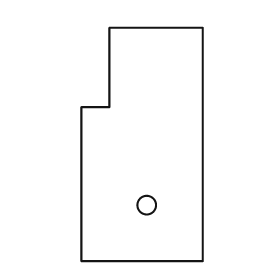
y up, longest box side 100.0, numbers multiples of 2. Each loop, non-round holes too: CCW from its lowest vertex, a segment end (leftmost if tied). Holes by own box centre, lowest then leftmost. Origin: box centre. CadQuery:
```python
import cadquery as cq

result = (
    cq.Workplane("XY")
    .moveTo(-26.0, -50.0)
    .lineTo(26.0, -50.0)
    .lineTo(26.0, 50.0)
    .lineTo(-14.0, 50.0)
    .lineTo(-14.0, 16.0)
    .lineTo(-26.0, 16.0)
    .close()
    .moveTo(2.0, -26.0)
    .circle(4.0)
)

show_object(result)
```